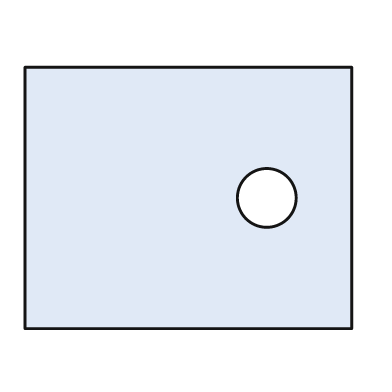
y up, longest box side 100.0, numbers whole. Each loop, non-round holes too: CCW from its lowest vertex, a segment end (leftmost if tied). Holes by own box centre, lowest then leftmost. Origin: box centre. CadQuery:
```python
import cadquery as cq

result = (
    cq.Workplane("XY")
    .moveTo(-50.0, -40.0)
    .lineTo(50.0, -40.0)
    .lineTo(50.0, 40.0)
    .lineTo(-50.0, 40.0)
    .close()
    .moveTo(24.0, 0.0)
    .circle(9.0)
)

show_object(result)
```